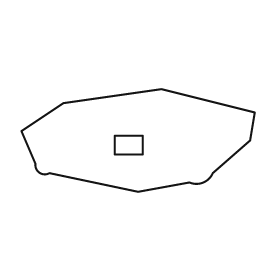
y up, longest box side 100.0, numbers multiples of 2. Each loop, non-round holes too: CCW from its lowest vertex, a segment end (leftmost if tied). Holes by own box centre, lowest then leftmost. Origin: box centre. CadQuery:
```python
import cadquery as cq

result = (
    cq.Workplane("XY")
    .moveTo(0.0, -22.0)
    .lineTo(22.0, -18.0)
    .threePointArc((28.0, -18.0), (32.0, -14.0))
    .lineTo(48.0, 0.0)
    .lineTo(50.0, 12.0)
    .lineTo(10.0, 22.0)
    .lineTo(-32.0, 16.0)
    .lineTo(-50.0, 4.0)
    .lineTo(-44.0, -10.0)
    .threePointArc((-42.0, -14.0), (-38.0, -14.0))
    .close()
    .moveTo(-10.0, -6.0)
    .lineTo(2.0, -6.0)
    .lineTo(2.0, 2.0)
    .lineTo(-10.0, 2.0)
    .close()
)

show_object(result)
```